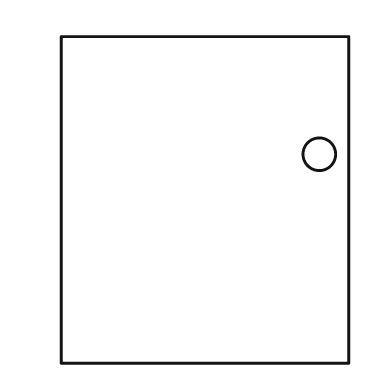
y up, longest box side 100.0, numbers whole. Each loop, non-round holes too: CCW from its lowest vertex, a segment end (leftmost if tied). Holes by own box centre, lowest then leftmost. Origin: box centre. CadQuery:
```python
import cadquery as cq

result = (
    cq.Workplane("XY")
    .moveTo(-44.0, -50.0)
    .lineTo(44.0, -50.0)
    .lineTo(44.0, 50.0)
    .lineTo(-44.0, 50.0)
    .close()
    .moveTo(35.0, 14.0)
    .circle(5.0)
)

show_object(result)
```